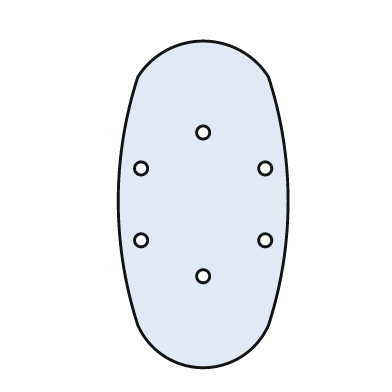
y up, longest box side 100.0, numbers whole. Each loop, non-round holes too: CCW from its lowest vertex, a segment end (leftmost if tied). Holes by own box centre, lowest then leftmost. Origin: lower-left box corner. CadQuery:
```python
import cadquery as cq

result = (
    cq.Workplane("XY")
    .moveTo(6.0, 13.0)
    .threePointArc((26.0, 0.0), (46.0, 13.0))
    .threePointArc((52.0, 51.0), (46.0, 89.0))
    .threePointArc((26.0, 100.0), (6.0, 89.0))
    .threePointArc((0.0, 51.0), (6.0, 13.0))
    .close()
    .moveTo(26.0, 28.0)
    .circle(2.0)
    .moveTo(7.0, 39.0)
    .circle(2.0)
    .moveTo(45.0, 39.0)
    .circle(2.0)
    .moveTo(7.0, 61.0)
    .circle(2.0)
    .moveTo(45.0, 61.0)
    .circle(2.0)
    .moveTo(26.0, 72.0)
    .circle(2.0)
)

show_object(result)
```